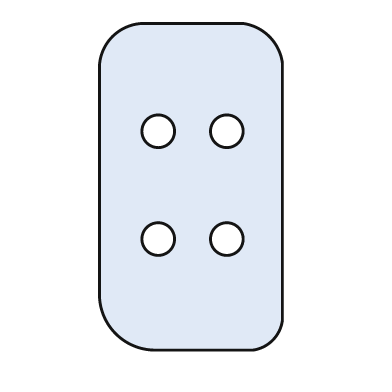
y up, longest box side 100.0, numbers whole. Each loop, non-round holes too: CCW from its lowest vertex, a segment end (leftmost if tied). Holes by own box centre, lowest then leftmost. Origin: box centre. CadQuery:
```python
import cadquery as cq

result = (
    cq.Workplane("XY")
    .moveTo(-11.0, -50.0)
    .lineTo(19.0, -50.0)
    .threePointArc((25.0, -47.0), (28.0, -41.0))
    .lineTo(28.0, 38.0)
    .threePointArc((24.0, 46.0), (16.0, 50.0))
    .lineTo(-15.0, 50.0)
    .threePointArc((-24.0, 46.0), (-28.0, 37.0))
    .lineTo(-28.0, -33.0)
    .threePointArc((-23.0, -45.0), (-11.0, -50.0))
    .close()
    .moveTo(-10.0, -16.0)
    .circle(5.0)
    .moveTo(11.0, -16.0)
    .circle(5.0)
    .moveTo(-10.0, 17.0)
    .circle(5.0)
    .moveTo(11.0, 17.0)
    .circle(5.0)
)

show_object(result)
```